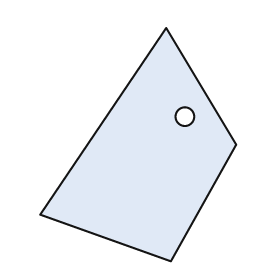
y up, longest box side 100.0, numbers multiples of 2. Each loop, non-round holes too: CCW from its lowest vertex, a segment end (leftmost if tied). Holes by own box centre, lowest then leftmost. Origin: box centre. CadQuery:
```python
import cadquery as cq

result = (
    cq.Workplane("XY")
    .moveTo(14.0, -50.0)
    .lineTo(42.0, 0.0)
    .lineTo(12.0, 50.0)
    .lineTo(-42.0, -30.0)
    .close()
    .moveTo(20.0, 12.0)
    .circle(4.0)
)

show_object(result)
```